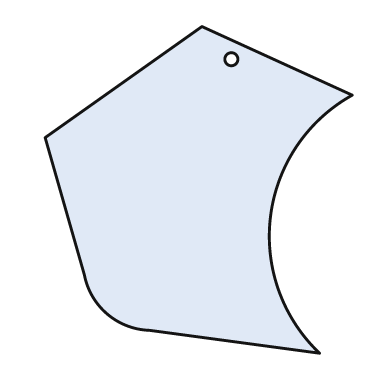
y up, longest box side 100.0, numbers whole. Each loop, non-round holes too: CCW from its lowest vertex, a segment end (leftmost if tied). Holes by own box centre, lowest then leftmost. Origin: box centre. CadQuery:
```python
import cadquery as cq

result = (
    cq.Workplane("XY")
    .moveTo(37.0, -50.0)
    .threePointArc((22.0, -8.0), (47.0, 29.0))
    .lineTo(1.0, 50.0)
    .lineTo(-47.0, 16.0)
    .lineTo(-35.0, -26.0)
    .threePointArc((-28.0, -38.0), (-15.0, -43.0))
    .close()
    .moveTo(10.0, 40.0)
    .circle(2.0)
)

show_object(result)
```